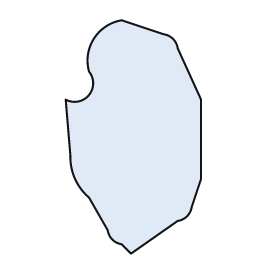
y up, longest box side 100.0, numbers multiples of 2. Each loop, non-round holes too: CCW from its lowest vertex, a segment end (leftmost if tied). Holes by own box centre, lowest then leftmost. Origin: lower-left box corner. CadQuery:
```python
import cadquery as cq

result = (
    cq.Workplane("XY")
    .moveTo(28.0, 0.0)
    .lineTo(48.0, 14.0)
    .threePointArc((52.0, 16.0), (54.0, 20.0))
    .lineTo(58.0, 32.0)
    .lineTo(58.0, 66.0)
    .lineTo(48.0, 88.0)
    .threePointArc((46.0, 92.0), (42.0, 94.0))
    .lineTo(24.0, 100.0)
    .threePointArc((12.0, 92.0), (10.0, 78.0))
    .threePointArc((10.0, 68.0), (0.0, 66.0))
    .lineTo(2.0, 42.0)
    .threePointArc((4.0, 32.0), (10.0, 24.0))
    .lineTo(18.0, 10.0)
    .threePointArc((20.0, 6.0), (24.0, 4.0))
    .close()
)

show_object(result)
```